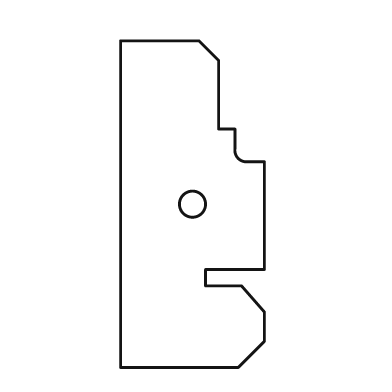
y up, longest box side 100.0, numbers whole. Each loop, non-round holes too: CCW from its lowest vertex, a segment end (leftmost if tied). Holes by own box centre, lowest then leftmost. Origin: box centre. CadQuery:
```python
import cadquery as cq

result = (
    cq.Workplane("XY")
    .moveTo(-22.0, -50.0)
    .lineTo(14.0, -50.0)
    .lineTo(22.0, -42.0)
    .lineTo(22.0, -33.0)
    .lineTo(15.0, -25.0)
    .lineTo(4.0, -25.0)
    .lineTo(4.0, -20.0)
    .lineTo(22.0, -20.0)
    .lineTo(22.0, 13.0)
    .lineTo(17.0, 13.0)
    .threePointArc((14.0, 14.0), (13.0, 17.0))
    .lineTo(13.0, 23.0)
    .lineTo(8.0, 23.0)
    .lineTo(8.0, 44.0)
    .lineTo(2.0, 50.0)
    .lineTo(-22.0, 50.0)
    .close()
    .moveTo(0.0, 0.0)
    .circle(4.0)
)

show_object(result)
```